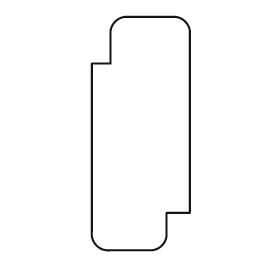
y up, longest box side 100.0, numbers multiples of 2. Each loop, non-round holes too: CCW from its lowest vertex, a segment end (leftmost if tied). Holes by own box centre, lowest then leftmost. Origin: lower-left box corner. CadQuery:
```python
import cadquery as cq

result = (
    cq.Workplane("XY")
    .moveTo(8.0, 0.0)
    .lineTo(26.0, 0.0)
    .threePointArc((30.0, 2.0), (32.0, 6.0))
    .lineTo(32.0, 16.0)
    .lineTo(42.0, 16.0)
    .lineTo(42.0, 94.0)
    .threePointArc((40.0, 98.0), (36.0, 100.0))
    .lineTo(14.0, 100.0)
    .threePointArc((10.0, 98.0), (8.0, 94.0))
    .lineTo(8.0, 80.0)
    .lineTo(0.0, 80.0)
    .lineTo(0.0, 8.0)
    .threePointArc((2.0, 2.0), (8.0, 0.0))
    .close()
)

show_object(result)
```